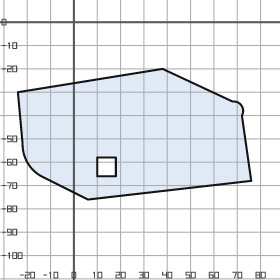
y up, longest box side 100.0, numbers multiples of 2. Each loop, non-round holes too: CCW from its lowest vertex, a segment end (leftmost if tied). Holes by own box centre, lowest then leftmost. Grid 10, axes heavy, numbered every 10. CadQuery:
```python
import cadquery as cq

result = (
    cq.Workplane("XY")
    .moveTo(6.0, -76.0)
    .lineTo(76.0, -68.0)
    .lineTo(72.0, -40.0)
    .threePointArc((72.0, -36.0), (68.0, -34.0))
    .lineTo(38.0, -20.0)
    .lineTo(-24.0, -30.0)
    .lineTo(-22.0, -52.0)
    .threePointArc((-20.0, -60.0), (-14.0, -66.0))
    .close()
    .moveTo(10.0, -66.0)
    .lineTo(18.0, -66.0)
    .lineTo(18.0, -58.0)
    .lineTo(10.0, -58.0)
    .close()
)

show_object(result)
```